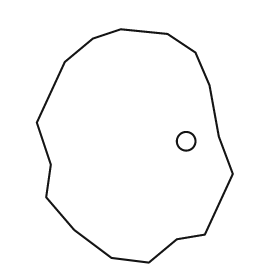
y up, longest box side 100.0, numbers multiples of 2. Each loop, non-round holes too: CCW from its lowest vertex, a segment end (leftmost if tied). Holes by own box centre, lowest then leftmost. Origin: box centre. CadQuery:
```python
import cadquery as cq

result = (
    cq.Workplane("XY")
    .moveTo(6.0, -50.0)
    .lineTo(18.0, -40.0)
    .lineTo(30.0, -38.0)
    .lineTo(42.0, -12.0)
    .lineTo(36.0, 4.0)
    .lineTo(32.0, 26.0)
    .lineTo(26.0, 40.0)
    .lineTo(14.0, 48.0)
    .lineTo(-6.0, 50.0)
    .lineTo(-18.0, 46.0)
    .lineTo(-30.0, 36.0)
    .lineTo(-42.0, 10.0)
    .lineTo(-36.0, -8.0)
    .lineTo(-38.0, -22.0)
    .lineTo(-26.0, -36.0)
    .lineTo(-10.0, -48.0)
    .close()
    .moveTo(22.0, 2.0)
    .circle(4.0)
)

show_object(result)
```